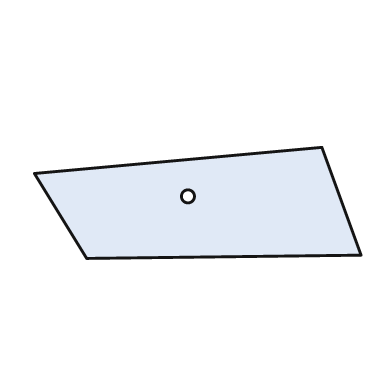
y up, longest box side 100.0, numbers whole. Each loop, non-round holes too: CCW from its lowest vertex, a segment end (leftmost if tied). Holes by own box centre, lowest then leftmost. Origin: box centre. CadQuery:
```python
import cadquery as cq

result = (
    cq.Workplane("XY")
    .moveTo(-34.0, -17.0)
    .lineTo(50.0, -16.0)
    .lineTo(38.0, 17.0)
    .lineTo(-50.0, 9.0)
    .close()
    .moveTo(-3.0, 2.0)
    .circle(2.0)
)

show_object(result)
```